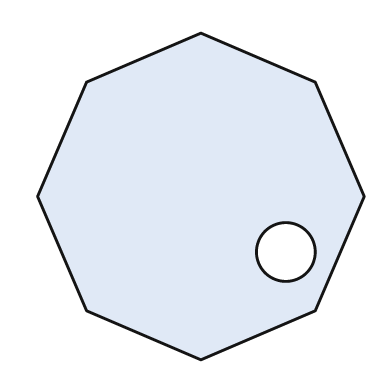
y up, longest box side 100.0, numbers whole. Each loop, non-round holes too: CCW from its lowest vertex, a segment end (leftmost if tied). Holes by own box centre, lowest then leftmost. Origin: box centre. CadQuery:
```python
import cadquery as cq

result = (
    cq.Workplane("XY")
    .moveTo(0.0, -50.0)
    .lineTo(35.0, -35.0)
    .lineTo(50.0, 0.0)
    .lineTo(35.0, 35.0)
    .lineTo(0.0, 50.0)
    .lineTo(-35.0, 35.0)
    .lineTo(-50.0, 0.0)
    .lineTo(-35.0, -35.0)
    .close()
    .moveTo(26.0, -17.0)
    .circle(9.0)
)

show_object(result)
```